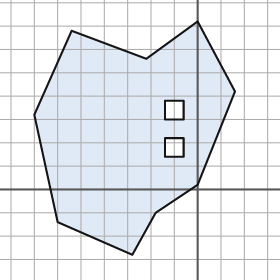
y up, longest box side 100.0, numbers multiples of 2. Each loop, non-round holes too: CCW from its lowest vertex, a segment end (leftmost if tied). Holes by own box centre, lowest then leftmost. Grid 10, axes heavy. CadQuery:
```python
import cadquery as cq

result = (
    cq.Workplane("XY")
    .moveTo(-28.0, -28.0)
    .lineTo(-18.0, -10.0)
    .lineTo(0.0, 2.0)
    .lineTo(16.0, 42.0)
    .lineTo(0.0, 72.0)
    .lineTo(-22.0, 56.0)
    .lineTo(-54.0, 68.0)
    .lineTo(-70.0, 32.0)
    .lineTo(-60.0, -14.0)
    .close()
    .moveTo(-14.0, 14.0)
    .lineTo(-6.0, 14.0)
    .lineTo(-6.0, 22.0)
    .lineTo(-14.0, 22.0)
    .close()
    .moveTo(-14.0, 30.0)
    .lineTo(-6.0, 30.0)
    .lineTo(-6.0, 38.0)
    .lineTo(-14.0, 38.0)
    .close()
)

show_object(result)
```